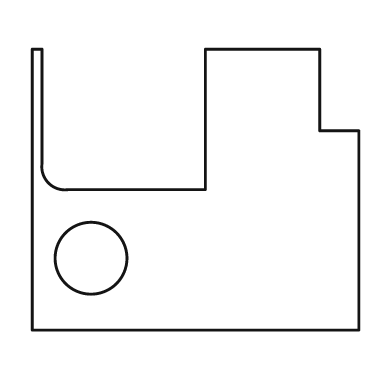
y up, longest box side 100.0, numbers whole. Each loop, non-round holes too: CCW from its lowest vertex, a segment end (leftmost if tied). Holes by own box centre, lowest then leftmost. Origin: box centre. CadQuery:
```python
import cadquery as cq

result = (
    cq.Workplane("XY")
    .moveTo(-50.0, -43.0)
    .lineTo(50.0, -43.0)
    .lineTo(50.0, 18.0)
    .lineTo(38.0, 18.0)
    .lineTo(38.0, 43.0)
    .lineTo(3.0, 43.0)
    .lineTo(3.0, 0.0)
    .lineTo(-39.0, 0.0)
    .threePointArc((-45.0, 2.0), (-47.0, 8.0))
    .lineTo(-47.0, 43.0)
    .lineTo(-50.0, 43.0)
    .close()
    .moveTo(-32.0, -21.0)
    .circle(11.0)
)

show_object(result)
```